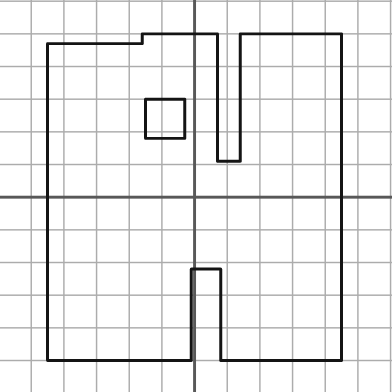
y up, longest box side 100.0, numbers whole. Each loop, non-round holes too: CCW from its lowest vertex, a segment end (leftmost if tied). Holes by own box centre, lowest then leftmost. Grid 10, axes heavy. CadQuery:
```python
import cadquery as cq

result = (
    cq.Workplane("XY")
    .moveTo(-45.0, -50.0)
    .lineTo(-1.0, -50.0)
    .lineTo(-1.0, -22.0)
    .lineTo(8.0, -22.0)
    .lineTo(8.0, -50.0)
    .lineTo(45.0, -50.0)
    .lineTo(45.0, 50.0)
    .lineTo(14.0, 50.0)
    .lineTo(14.0, 11.0)
    .lineTo(7.0, 11.0)
    .lineTo(7.0, 50.0)
    .lineTo(-16.0, 50.0)
    .lineTo(-16.0, 47.0)
    .lineTo(-45.0, 47.0)
    .close()
    .moveTo(-15.0, 18.0)
    .lineTo(-3.0, 18.0)
    .lineTo(-3.0, 30.0)
    .lineTo(-15.0, 30.0)
    .close()
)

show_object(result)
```